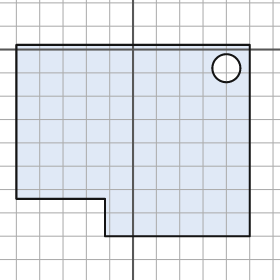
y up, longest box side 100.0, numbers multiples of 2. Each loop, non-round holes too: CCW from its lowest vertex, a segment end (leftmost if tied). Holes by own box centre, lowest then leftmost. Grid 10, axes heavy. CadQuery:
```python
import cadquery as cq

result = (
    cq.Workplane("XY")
    .moveTo(-12.0, -80.0)
    .lineTo(50.0, -80.0)
    .lineTo(50.0, 2.0)
    .lineTo(-50.0, 2.0)
    .lineTo(-50.0, -64.0)
    .lineTo(-12.0, -64.0)
    .close()
    .moveTo(40.0, -8.0)
    .circle(6.0)
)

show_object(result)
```